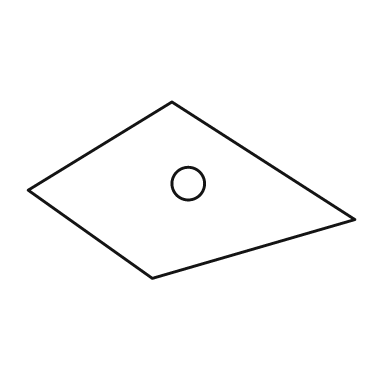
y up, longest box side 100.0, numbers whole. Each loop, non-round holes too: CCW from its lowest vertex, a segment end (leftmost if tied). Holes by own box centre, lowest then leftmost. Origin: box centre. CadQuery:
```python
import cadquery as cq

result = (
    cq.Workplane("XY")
    .moveTo(-12.0, -27.0)
    .lineTo(50.0, -9.0)
    .lineTo(-6.0, 27.0)
    .lineTo(-50.0, 0.0)
    .close()
    .moveTo(-1.0, 2.0)
    .circle(5.0)
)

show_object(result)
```